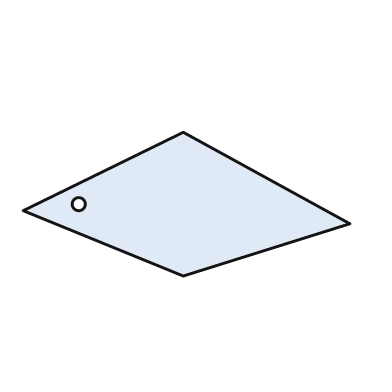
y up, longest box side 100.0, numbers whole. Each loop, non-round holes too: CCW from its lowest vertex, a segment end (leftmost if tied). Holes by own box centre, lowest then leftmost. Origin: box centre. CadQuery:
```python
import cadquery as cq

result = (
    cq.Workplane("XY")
    .moveTo(-1.0, -22.0)
    .lineTo(50.0, -6.0)
    .lineTo(-1.0, 22.0)
    .lineTo(-50.0, -2.0)
    .close()
    .moveTo(-33.0, 0.0)
    .circle(2.0)
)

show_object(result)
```